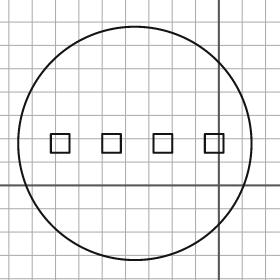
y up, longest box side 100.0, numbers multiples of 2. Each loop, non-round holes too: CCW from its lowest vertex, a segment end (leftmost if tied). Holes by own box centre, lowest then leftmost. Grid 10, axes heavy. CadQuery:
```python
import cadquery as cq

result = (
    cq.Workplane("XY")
    .moveTo(-36.0, 18.0)
    .circle(50.0)
    .moveTo(-72.0, 14.0)
    .lineTo(-64.0, 14.0)
    .lineTo(-64.0, 22.0)
    .lineTo(-72.0, 22.0)
    .close()
    .moveTo(-50.0, 14.0)
    .lineTo(-42.0, 14.0)
    .lineTo(-42.0, 22.0)
    .lineTo(-50.0, 22.0)
    .close()
    .moveTo(-28.0, 14.0)
    .lineTo(-20.0, 14.0)
    .lineTo(-20.0, 22.0)
    .lineTo(-28.0, 22.0)
    .close()
    .moveTo(-6.0, 14.0)
    .lineTo(2.0, 14.0)
    .lineTo(2.0, 22.0)
    .lineTo(-6.0, 22.0)
    .close()
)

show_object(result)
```